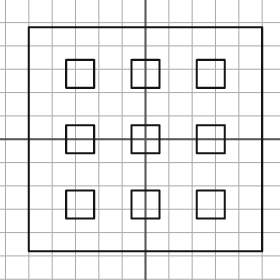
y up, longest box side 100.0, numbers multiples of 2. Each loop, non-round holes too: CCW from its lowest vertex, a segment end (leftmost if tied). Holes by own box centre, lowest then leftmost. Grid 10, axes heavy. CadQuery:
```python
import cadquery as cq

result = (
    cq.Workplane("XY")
    .moveTo(-50.0, -48.0)
    .lineTo(50.0, -48.0)
    .lineTo(50.0, 48.0)
    .lineTo(-50.0, 48.0)
    .close()
    .moveTo(-34.0, -34.0)
    .lineTo(-22.0, -34.0)
    .lineTo(-22.0, -22.0)
    .lineTo(-34.0, -22.0)
    .close()
    .moveTo(-6.0, -34.0)
    .lineTo(6.0, -34.0)
    .lineTo(6.0, -22.0)
    .lineTo(-6.0, -22.0)
    .close()
    .moveTo(22.0, -34.0)
    .lineTo(34.0, -34.0)
    .lineTo(34.0, -22.0)
    .lineTo(22.0, -22.0)
    .close()
    .moveTo(-34.0, -6.0)
    .lineTo(-22.0, -6.0)
    .lineTo(-22.0, 6.0)
    .lineTo(-34.0, 6.0)
    .close()
    .moveTo(-6.0, -6.0)
    .lineTo(6.0, -6.0)
    .lineTo(6.0, 6.0)
    .lineTo(-6.0, 6.0)
    .close()
    .moveTo(22.0, -6.0)
    .lineTo(34.0, -6.0)
    .lineTo(34.0, 6.0)
    .lineTo(22.0, 6.0)
    .close()
    .moveTo(-34.0, 22.0)
    .lineTo(-22.0, 22.0)
    .lineTo(-22.0, 34.0)
    .lineTo(-34.0, 34.0)
    .close()
    .moveTo(-6.0, 22.0)
    .lineTo(6.0, 22.0)
    .lineTo(6.0, 34.0)
    .lineTo(-6.0, 34.0)
    .close()
    .moveTo(22.0, 22.0)
    .lineTo(34.0, 22.0)
    .lineTo(34.0, 34.0)
    .lineTo(22.0, 34.0)
    .close()
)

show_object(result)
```